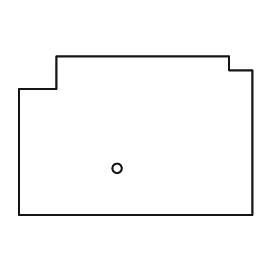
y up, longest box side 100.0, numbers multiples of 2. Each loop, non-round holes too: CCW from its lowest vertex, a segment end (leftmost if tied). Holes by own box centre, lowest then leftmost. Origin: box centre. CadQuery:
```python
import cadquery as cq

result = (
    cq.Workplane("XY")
    .moveTo(-50.0, -34.0)
    .lineTo(50.0, -34.0)
    .lineTo(50.0, 28.0)
    .lineTo(40.0, 28.0)
    .lineTo(40.0, 34.0)
    .lineTo(-34.0, 34.0)
    .lineTo(-34.0, 20.0)
    .lineTo(-50.0, 20.0)
    .close()
    .moveTo(-8.0, -14.0)
    .circle(2.0)
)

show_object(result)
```